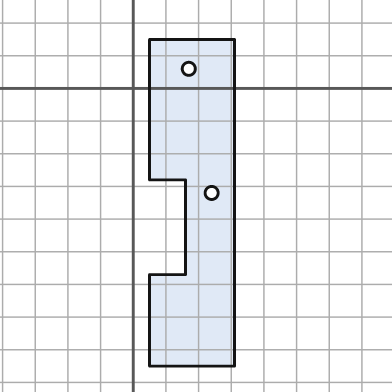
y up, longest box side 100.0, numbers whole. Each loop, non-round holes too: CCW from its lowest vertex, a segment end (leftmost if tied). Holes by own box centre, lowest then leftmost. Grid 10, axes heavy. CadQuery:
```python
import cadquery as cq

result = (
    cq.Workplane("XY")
    .moveTo(5.0, -85.0)
    .lineTo(31.0, -85.0)
    .lineTo(31.0, 15.0)
    .lineTo(5.0, 15.0)
    .lineTo(5.0, -28.0)
    .lineTo(16.0, -28.0)
    .lineTo(16.0, -57.0)
    .lineTo(5.0, -57.0)
    .close()
    .moveTo(24.0, -32.0)
    .circle(2.0)
    .moveTo(17.0, 6.0)
    .circle(2.0)
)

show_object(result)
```